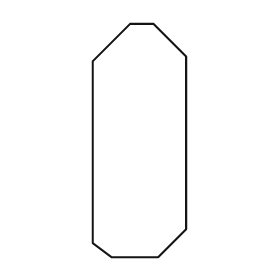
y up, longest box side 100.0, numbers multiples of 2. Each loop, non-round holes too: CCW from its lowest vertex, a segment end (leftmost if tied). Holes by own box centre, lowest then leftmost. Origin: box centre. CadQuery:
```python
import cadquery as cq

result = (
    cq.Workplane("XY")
    .moveTo(-12.0, -50.0)
    .lineTo(8.0, -50.0)
    .lineTo(20.0, -38.0)
    .lineTo(20.0, 36.0)
    .lineTo(6.0, 50.0)
    .lineTo(-4.0, 50.0)
    .lineTo(-20.0, 34.0)
    .lineTo(-20.0, -44.0)
    .close()
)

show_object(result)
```